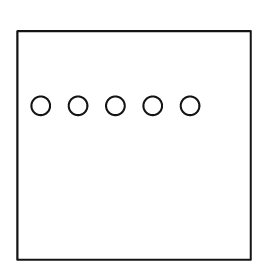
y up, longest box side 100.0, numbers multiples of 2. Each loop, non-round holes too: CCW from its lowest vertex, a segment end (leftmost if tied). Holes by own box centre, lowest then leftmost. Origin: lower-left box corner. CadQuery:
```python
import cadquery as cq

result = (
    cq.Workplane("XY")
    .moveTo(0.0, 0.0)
    .lineTo(100.0, 0.0)
    .lineTo(100.0, 98.0)
    .lineTo(0.0, 98.0)
    .close()
    .moveTo(10.0, 66.0)
    .circle(4.0)
    .moveTo(26.0, 66.0)
    .circle(4.0)
    .moveTo(42.0, 66.0)
    .circle(4.0)
    .moveTo(58.0, 66.0)
    .circle(4.0)
    .moveTo(74.0, 66.0)
    .circle(4.0)
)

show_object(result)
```